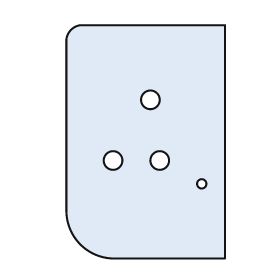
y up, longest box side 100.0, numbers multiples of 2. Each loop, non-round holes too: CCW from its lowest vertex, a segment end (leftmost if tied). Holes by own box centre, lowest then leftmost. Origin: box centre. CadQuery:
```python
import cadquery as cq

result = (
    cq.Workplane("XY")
    .moveTo(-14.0, -50.0)
    .lineTo(34.0, -50.0)
    .lineTo(34.0, 50.0)
    .lineTo(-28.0, 50.0)
    .threePointArc((-32.0, 48.0), (-34.0, 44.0))
    .lineTo(-34.0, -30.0)
    .threePointArc((-28.0, -44.0), (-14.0, -50.0))
    .close()
    .moveTo(24.0, -18.0)
    .circle(2.0)
    .moveTo(-14.0, -8.0)
    .circle(4.0)
    .moveTo(6.0, -8.0)
    .circle(4.0)
    .moveTo(2.0, 18.0)
    .circle(4.0)
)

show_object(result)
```